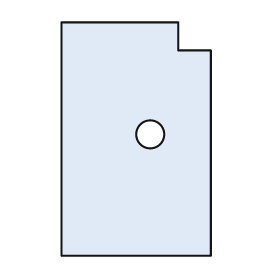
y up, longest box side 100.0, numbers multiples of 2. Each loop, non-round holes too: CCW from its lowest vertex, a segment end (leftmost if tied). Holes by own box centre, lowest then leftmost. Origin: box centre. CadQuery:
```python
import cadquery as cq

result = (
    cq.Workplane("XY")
    .moveTo(-32.0, -50.0)
    .lineTo(32.0, -50.0)
    .lineTo(32.0, 38.0)
    .lineTo(18.0, 38.0)
    .lineTo(18.0, 50.0)
    .lineTo(-32.0, 50.0)
    .close()
    .moveTo(6.0, 2.0)
    .circle(6.0)
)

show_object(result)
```